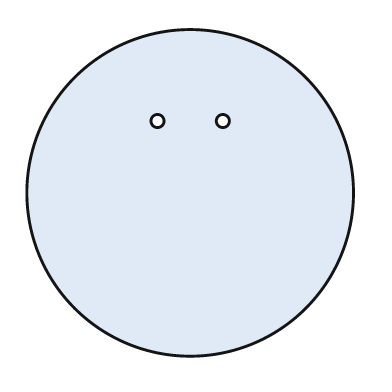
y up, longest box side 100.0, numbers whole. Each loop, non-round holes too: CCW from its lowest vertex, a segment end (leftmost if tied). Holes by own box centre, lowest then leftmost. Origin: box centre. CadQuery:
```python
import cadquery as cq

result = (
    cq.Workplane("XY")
    .moveTo(0.0, 0.0)
    .circle(50.0)
    .moveTo(-10.0, 22.0)
    .circle(2.0)
    .moveTo(10.0, 22.0)
    .circle(2.0)
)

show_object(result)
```